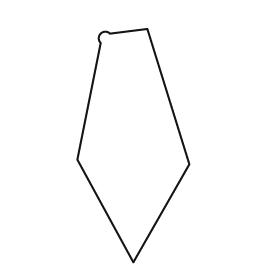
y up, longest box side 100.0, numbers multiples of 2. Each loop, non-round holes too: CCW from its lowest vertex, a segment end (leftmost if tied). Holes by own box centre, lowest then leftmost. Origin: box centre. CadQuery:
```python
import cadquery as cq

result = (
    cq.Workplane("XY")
    .moveTo(0.0, -50.0)
    .lineTo(24.0, -8.0)
    .lineTo(6.0, 50.0)
    .lineTo(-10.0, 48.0)
    .threePointArc((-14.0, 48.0), (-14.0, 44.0))
    .lineTo(-24.0, -6.0)
    .close()
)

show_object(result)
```